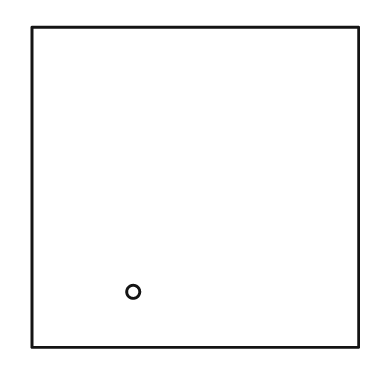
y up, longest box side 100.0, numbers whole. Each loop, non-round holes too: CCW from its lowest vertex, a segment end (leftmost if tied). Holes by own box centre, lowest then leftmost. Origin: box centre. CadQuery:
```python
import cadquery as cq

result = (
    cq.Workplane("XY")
    .moveTo(-50.0, -49.0)
    .lineTo(50.0, -49.0)
    .lineTo(50.0, 49.0)
    .lineTo(-50.0, 49.0)
    .close()
    .moveTo(-19.0, -32.0)
    .circle(2.0)
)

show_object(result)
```